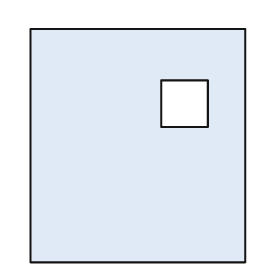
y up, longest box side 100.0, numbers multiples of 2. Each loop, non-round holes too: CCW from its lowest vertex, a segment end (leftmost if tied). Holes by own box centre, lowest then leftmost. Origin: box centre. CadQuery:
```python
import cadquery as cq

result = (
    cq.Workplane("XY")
    .moveTo(-46.0, -50.0)
    .lineTo(46.0, -50.0)
    .lineTo(46.0, 50.0)
    .lineTo(-46.0, 50.0)
    .close()
    .moveTo(10.0, 8.0)
    .lineTo(30.0, 8.0)
    .lineTo(30.0, 28.0)
    .lineTo(10.0, 28.0)
    .close()
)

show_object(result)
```